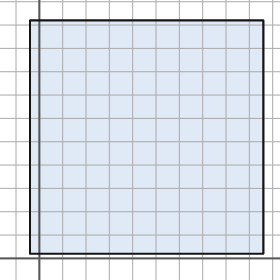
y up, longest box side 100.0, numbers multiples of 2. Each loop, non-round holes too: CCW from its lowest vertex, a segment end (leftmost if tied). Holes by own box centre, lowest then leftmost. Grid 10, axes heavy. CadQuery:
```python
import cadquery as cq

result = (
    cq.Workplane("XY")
    .moveTo(-4.0, 2.0)
    .lineTo(96.0, 2.0)
    .lineTo(96.0, 102.0)
    .lineTo(-4.0, 102.0)
    .close()
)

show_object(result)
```